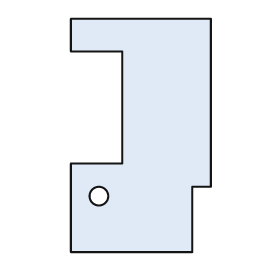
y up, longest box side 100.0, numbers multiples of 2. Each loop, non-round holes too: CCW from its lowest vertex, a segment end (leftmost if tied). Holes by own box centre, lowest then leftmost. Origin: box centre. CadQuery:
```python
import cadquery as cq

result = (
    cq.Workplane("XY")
    .moveTo(-30.0, -50.0)
    .lineTo(22.0, -50.0)
    .lineTo(22.0, -22.0)
    .lineTo(30.0, -22.0)
    .lineTo(30.0, 50.0)
    .lineTo(-30.0, 50.0)
    .lineTo(-30.0, 36.0)
    .lineTo(-8.0, 36.0)
    .lineTo(-8.0, -12.0)
    .lineTo(-30.0, -12.0)
    .close()
    .moveTo(-18.0, -26.0)
    .circle(4.0)
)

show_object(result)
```